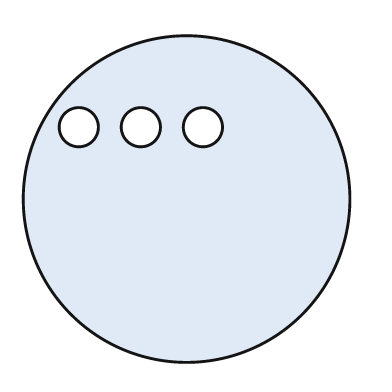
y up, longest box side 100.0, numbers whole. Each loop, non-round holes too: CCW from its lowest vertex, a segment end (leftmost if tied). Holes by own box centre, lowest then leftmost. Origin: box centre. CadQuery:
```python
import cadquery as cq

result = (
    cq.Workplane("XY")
    .moveTo(0.0, 0.0)
    .circle(50.0)
    .moveTo(-33.0, 22.0)
    .circle(6.0)
    .moveTo(-14.0, 22.0)
    .circle(6.0)
    .moveTo(5.0, 22.0)
    .circle(6.0)
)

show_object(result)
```